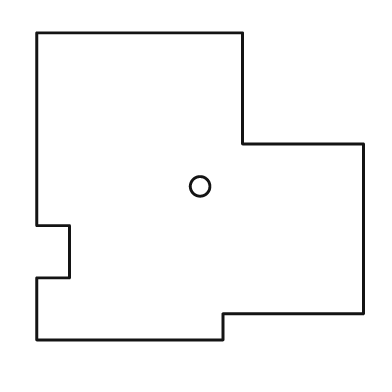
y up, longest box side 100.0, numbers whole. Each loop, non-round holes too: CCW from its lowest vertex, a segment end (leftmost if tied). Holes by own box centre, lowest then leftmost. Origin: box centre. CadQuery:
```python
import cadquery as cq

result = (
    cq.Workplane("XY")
    .moveTo(-50.0, -47.0)
    .lineTo(7.0, -47.0)
    .lineTo(7.0, -39.0)
    .lineTo(50.0, -39.0)
    .lineTo(50.0, 13.0)
    .lineTo(13.0, 13.0)
    .lineTo(13.0, 47.0)
    .lineTo(-50.0, 47.0)
    .lineTo(-50.0, -12.0)
    .lineTo(-40.0, -12.0)
    .lineTo(-40.0, -28.0)
    .lineTo(-50.0, -28.0)
    .close()
    .moveTo(0.0, 0.0)
    .circle(3.0)
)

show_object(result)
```